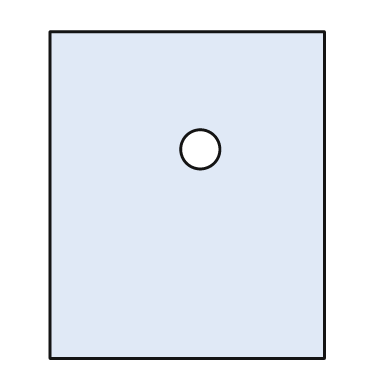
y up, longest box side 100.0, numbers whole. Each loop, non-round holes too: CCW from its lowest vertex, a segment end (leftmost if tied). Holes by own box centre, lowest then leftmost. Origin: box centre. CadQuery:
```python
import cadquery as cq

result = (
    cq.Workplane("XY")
    .moveTo(-42.0, -50.0)
    .lineTo(42.0, -50.0)
    .lineTo(42.0, 50.0)
    .lineTo(-42.0, 50.0)
    .close()
    .moveTo(4.0, 14.0)
    .circle(6.0)
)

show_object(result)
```